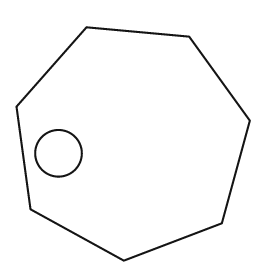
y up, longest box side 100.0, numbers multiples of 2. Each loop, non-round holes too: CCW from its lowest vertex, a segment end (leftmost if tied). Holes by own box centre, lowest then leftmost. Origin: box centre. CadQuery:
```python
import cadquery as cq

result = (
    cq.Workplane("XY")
    .moveTo(-4.0, -50.0)
    .lineTo(38.0, -34.0)
    .lineTo(50.0, 10.0)
    .lineTo(24.0, 46.0)
    .lineTo(-20.0, 50.0)
    .lineTo(-50.0, 16.0)
    .lineTo(-44.0, -28.0)
    .close()
    .moveTo(-32.0, -4.0)
    .circle(10.0)
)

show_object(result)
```